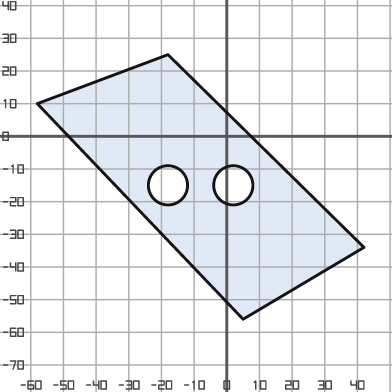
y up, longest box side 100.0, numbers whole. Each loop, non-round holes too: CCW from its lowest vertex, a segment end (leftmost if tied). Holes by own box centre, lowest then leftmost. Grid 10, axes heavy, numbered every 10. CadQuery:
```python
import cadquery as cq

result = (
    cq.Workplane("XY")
    .moveTo(5.0, -56.0)
    .lineTo(42.0, -34.0)
    .lineTo(-18.0, 25.0)
    .lineTo(-58.0, 10.0)
    .close()
    .moveTo(-18.0, -15.0)
    .circle(6.0)
    .moveTo(2.0, -15.0)
    .circle(6.0)
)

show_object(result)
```